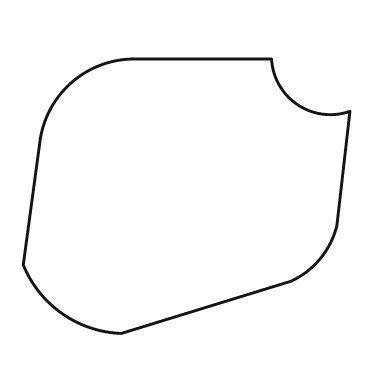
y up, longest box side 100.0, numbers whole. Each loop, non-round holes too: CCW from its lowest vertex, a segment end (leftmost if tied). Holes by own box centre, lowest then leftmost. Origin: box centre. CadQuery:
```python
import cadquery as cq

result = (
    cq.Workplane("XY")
    .moveTo(-20.0, -42.0)
    .lineTo(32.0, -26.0)
    .threePointArc((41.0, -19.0), (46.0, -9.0))
    .lineTo(50.0, 26.0)
    .threePointArc((34.0, 28.0), (26.0, 42.0))
    .lineTo(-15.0, 42.0)
    .threePointArc((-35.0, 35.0), (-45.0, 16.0))
    .lineTo(-50.0, -21.0)
    .threePointArc((-38.0, -36.0), (-20.0, -42.0))
    .close()
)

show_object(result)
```